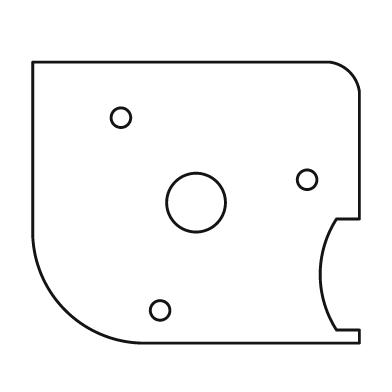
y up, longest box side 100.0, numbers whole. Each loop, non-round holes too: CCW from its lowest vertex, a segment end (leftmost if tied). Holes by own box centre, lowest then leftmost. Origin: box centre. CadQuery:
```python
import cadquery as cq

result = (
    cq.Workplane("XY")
    .moveTo(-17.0, -43.0)
    .lineTo(50.0, -43.0)
    .lineTo(50.0, -39.0)
    .lineTo(43.0, -39.0)
    .threePointArc((38.0, -22.0), (43.0, -5.0))
    .lineTo(50.0, -5.0)
    .lineTo(50.0, 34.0)
    .threePointArc((47.0, 40.0), (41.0, 43.0))
    .lineTo(-50.0, 43.0)
    .lineTo(-50.0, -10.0)
    .threePointArc((-40.0, -33.0), (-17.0, -43.0))
    .close()
    .moveTo(-11.0, -33.0)
    .circle(3.0)
    .moveTo(0.0, 0.0)
    .circle(9.0)
    .moveTo(34.0, 7.0)
    .circle(3.0)
    .moveTo(-23.0, 26.0)
    .circle(3.0)
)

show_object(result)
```